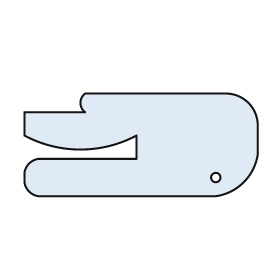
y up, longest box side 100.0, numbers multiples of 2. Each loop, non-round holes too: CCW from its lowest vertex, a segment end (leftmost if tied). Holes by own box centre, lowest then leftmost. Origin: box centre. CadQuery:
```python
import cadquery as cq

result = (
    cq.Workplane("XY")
    .moveTo(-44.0, -22.0)
    .lineTo(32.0, -22.0)
    .threePointArc((44.0, -16.0), (50.0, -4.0))
    .lineTo(50.0, 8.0)
    .threePointArc((46.0, 18.0), (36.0, 22.0))
    .lineTo(-24.0, 22.0)
    .threePointArc((-26.0, 18.0), (-24.0, 14.0))
    .lineTo(-50.0, 14.0)
    .lineTo(-50.0, 4.0)
    .threePointArc((-26.0, -2.0), (-2.0, 4.0))
    .lineTo(-2.0, -6.0)
    .lineTo(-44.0, -6.0)
    .threePointArc((-48.0, -8.0), (-50.0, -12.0))
    .lineTo(-50.0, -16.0)
    .threePointArc((-48.0, -20.0), (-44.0, -22.0))
    .close()
    .moveTo(32.0, -14.0)
    .circle(2.0)
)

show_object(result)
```